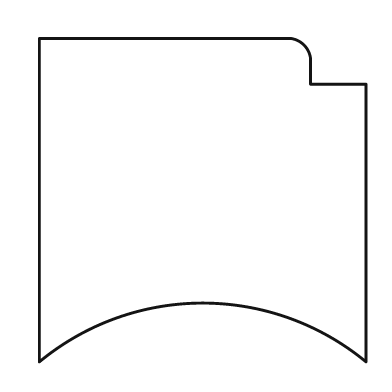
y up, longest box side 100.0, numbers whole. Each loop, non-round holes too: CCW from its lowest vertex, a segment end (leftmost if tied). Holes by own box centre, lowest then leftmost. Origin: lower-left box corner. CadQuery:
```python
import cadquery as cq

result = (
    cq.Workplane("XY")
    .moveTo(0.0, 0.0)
    .threePointArc((50.0, 18.0), (100.0, 0.0))
    .lineTo(100.0, 85.0)
    .lineTo(83.0, 85.0)
    .lineTo(83.0, 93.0)
    .threePointArc((81.0, 97.0), (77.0, 99.0))
    .lineTo(0.0, 99.0)
    .close()
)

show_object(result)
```